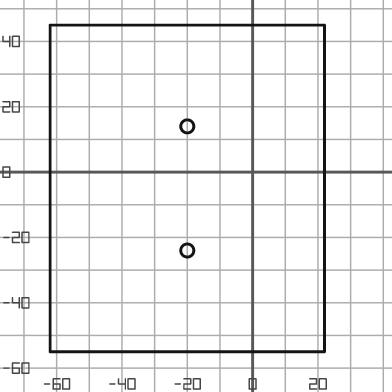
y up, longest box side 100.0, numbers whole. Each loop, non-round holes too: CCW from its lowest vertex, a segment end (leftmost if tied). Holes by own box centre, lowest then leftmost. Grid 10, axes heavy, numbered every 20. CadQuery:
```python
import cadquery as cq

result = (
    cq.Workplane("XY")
    .moveTo(-62.0, -55.0)
    .lineTo(22.0, -55.0)
    .lineTo(22.0, 45.0)
    .lineTo(-62.0, 45.0)
    .close()
    .moveTo(-20.0, -24.0)
    .circle(2.0)
    .moveTo(-20.0, 14.0)
    .circle(2.0)
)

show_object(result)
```